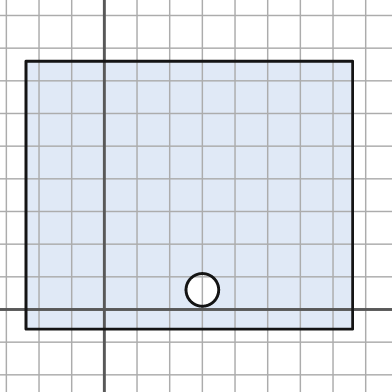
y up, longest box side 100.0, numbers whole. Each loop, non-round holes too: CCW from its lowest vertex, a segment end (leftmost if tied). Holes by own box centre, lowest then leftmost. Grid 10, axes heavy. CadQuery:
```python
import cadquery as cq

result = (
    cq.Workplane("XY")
    .moveTo(-24.0, -6.0)
    .lineTo(76.0, -6.0)
    .lineTo(76.0, 76.0)
    .lineTo(-24.0, 76.0)
    .close()
    .moveTo(30.0, 6.0)
    .circle(5.0)
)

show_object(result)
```